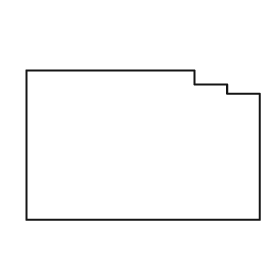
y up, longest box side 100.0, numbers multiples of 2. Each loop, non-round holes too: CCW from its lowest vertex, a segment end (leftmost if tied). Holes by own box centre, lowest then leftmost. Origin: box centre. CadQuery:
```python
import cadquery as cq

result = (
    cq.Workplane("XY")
    .moveTo(-50.0, -32.0)
    .lineTo(50.0, -32.0)
    .lineTo(50.0, 22.0)
    .lineTo(36.0, 22.0)
    .lineTo(36.0, 26.0)
    .lineTo(22.0, 26.0)
    .lineTo(22.0, 32.0)
    .lineTo(-50.0, 32.0)
    .close()
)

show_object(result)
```